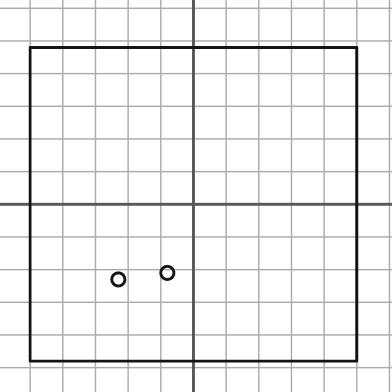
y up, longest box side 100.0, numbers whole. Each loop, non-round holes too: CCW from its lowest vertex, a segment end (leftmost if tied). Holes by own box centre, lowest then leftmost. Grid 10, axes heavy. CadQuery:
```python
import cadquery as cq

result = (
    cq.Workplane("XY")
    .moveTo(-50.0, -48.0)
    .lineTo(50.0, -48.0)
    .lineTo(50.0, 48.0)
    .lineTo(-50.0, 48.0)
    .close()
    .moveTo(-23.0, -23.0)
    .circle(2.0)
    .moveTo(-8.0, -21.0)
    .circle(2.0)
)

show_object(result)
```